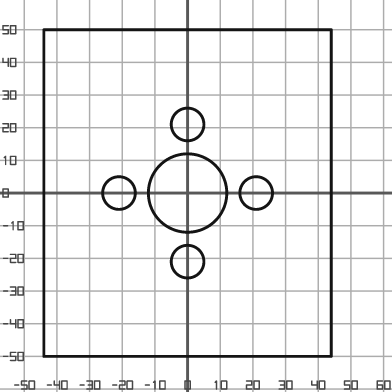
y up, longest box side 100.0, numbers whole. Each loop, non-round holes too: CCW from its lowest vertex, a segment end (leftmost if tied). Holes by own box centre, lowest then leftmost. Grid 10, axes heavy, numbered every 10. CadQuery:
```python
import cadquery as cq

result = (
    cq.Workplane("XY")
    .moveTo(-44.0, -50.0)
    .lineTo(44.0, -50.0)
    .lineTo(44.0, 50.0)
    .lineTo(-44.0, 50.0)
    .close()
    .moveTo(0.0, -21.0)
    .circle(5.0)
    .moveTo(-21.0, 0.0)
    .circle(5.0)
    .moveTo(0.0, 0.0)
    .circle(12.0)
    .moveTo(21.0, 0.0)
    .circle(5.0)
    .moveTo(0.0, 21.0)
    .circle(5.0)
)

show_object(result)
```